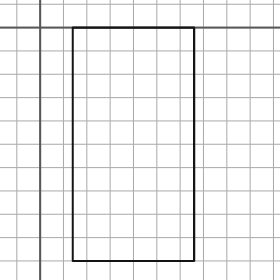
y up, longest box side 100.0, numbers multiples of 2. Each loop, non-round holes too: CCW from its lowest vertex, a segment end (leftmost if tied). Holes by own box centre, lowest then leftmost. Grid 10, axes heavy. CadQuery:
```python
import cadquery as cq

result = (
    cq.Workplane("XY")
    .moveTo(14.0, -100.0)
    .lineTo(66.0, -100.0)
    .lineTo(66.0, 0.0)
    .lineTo(14.0, 0.0)
    .close()
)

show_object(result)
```